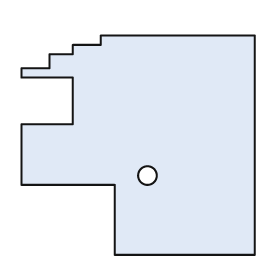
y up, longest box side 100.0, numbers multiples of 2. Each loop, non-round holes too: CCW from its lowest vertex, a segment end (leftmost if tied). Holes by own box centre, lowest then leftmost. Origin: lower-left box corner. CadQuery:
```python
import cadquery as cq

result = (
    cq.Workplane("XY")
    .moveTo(40.0, 0.0)
    .lineTo(100.0, 0.0)
    .lineTo(100.0, 94.0)
    .lineTo(34.0, 94.0)
    .lineTo(34.0, 90.0)
    .lineTo(22.0, 90.0)
    .lineTo(22.0, 86.0)
    .lineTo(12.0, 86.0)
    .lineTo(12.0, 80.0)
    .lineTo(0.0, 80.0)
    .lineTo(0.0, 76.0)
    .lineTo(22.0, 76.0)
    .lineTo(22.0, 56.0)
    .lineTo(0.0, 56.0)
    .lineTo(0.0, 30.0)
    .lineTo(40.0, 30.0)
    .close()
    .moveTo(54.0, 34.0)
    .circle(4.0)
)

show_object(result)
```